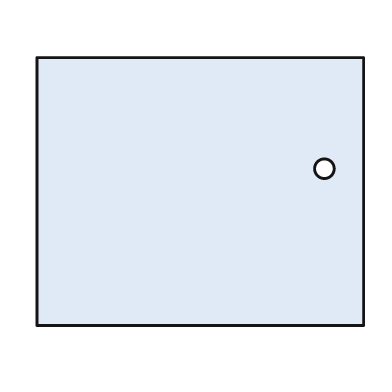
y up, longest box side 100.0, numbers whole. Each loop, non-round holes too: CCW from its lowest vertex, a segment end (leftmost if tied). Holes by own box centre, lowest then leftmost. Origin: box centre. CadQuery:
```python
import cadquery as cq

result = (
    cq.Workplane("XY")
    .moveTo(-50.0, -41.0)
    .lineTo(50.0, -41.0)
    .lineTo(50.0, 41.0)
    .lineTo(-50.0, 41.0)
    .close()
    .moveTo(38.0, 7.0)
    .circle(3.0)
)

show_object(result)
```